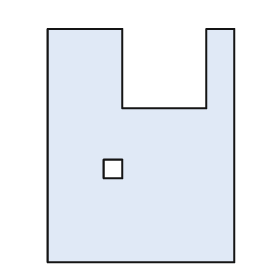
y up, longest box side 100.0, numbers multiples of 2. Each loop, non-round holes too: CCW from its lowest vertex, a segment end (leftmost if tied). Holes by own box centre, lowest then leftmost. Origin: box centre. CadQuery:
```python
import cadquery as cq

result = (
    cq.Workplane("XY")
    .moveTo(-40.0, -50.0)
    .lineTo(40.0, -50.0)
    .lineTo(40.0, 50.0)
    .lineTo(28.0, 50.0)
    .lineTo(28.0, 16.0)
    .lineTo(-8.0, 16.0)
    .lineTo(-8.0, 50.0)
    .lineTo(-40.0, 50.0)
    .close()
    .moveTo(-16.0, -14.0)
    .lineTo(-8.0, -14.0)
    .lineTo(-8.0, -6.0)
    .lineTo(-16.0, -6.0)
    .close()
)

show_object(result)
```